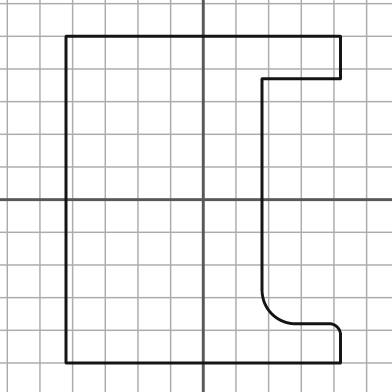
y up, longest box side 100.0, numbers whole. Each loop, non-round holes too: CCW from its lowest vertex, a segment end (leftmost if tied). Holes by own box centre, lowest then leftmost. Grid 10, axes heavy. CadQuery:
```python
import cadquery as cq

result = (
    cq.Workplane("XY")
    .moveTo(-42.0, -50.0)
    .lineTo(42.0, -50.0)
    .lineTo(42.0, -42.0)
    .threePointArc((41.0, -39.0), (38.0, -38.0))
    .lineTo(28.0, -38.0)
    .threePointArc((21.0, -35.0), (18.0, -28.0))
    .lineTo(18.0, 37.0)
    .lineTo(42.0, 37.0)
    .lineTo(42.0, 50.0)
    .lineTo(-42.0, 50.0)
    .close()
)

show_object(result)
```